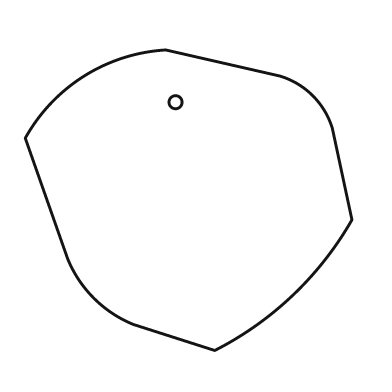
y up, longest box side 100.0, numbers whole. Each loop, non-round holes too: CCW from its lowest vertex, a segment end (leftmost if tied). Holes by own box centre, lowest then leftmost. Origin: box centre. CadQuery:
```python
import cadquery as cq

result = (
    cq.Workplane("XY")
    .moveTo(8.0, -46.0)
    .threePointArc((32.0, -29.0), (50.0, -6.0))
    .lineTo(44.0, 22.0)
    .threePointArc((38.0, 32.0), (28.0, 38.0))
    .lineTo(-7.0, 46.0)
    .threePointArc((-32.0, 38.0), (-50.0, 19.0))
    .lineTo(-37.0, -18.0)
    .threePointArc((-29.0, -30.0), (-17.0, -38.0))
    .close()
    .moveTo(-4.0, 30.0)
    .circle(2.0)
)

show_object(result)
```